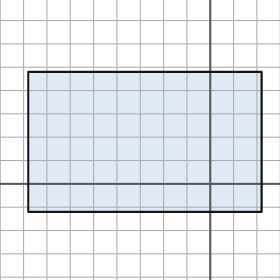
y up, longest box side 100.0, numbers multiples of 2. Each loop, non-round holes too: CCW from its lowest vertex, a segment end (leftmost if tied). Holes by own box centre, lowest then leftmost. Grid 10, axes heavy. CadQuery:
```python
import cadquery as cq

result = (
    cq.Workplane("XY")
    .moveTo(-78.0, -12.0)
    .lineTo(22.0, -12.0)
    .lineTo(22.0, 48.0)
    .lineTo(-78.0, 48.0)
    .close()
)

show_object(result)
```